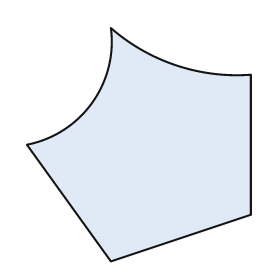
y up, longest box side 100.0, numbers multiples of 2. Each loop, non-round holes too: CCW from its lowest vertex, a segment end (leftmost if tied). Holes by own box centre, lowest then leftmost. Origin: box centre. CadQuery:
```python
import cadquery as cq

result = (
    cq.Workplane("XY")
    .moveTo(-12.0, -50.0)
    .lineTo(48.0, -30.0)
    .lineTo(48.0, 30.0)
    .threePointArc((16.0, 34.0), (-12.0, 50.0))
    .threePointArc((-20.0, 18.0), (-48.0, 0.0))
    .close()
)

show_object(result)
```